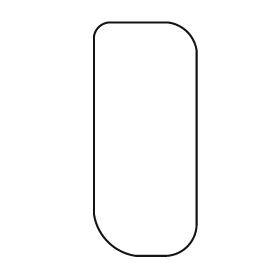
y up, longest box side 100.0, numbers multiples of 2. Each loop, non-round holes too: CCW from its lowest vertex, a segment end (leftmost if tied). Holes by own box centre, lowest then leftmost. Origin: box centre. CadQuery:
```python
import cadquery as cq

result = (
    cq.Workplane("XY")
    .moveTo(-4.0, -50.0)
    .lineTo(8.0, -50.0)
    .threePointArc((18.0, -46.0), (22.0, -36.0))
    .lineTo(22.0, 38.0)
    .threePointArc((18.0, 46.0), (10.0, 50.0))
    .lineTo(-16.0, 50.0)
    .threePointArc((-20.0, 48.0), (-22.0, 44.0))
    .lineTo(-22.0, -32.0)
    .threePointArc((-16.0, -44.0), (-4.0, -50.0))
    .close()
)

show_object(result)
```